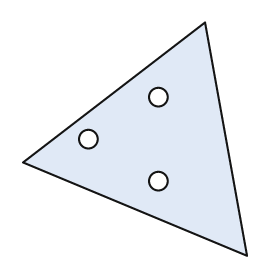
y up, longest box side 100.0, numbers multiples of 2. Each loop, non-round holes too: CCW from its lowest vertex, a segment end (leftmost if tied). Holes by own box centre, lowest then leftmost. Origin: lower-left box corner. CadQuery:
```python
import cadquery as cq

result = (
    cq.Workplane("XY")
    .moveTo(96.0, 0.0)
    .lineTo(78.0, 100.0)
    .lineTo(0.0, 40.0)
    .close()
    .moveTo(58.0, 32.0)
    .circle(4.0)
    .moveTo(28.0, 50.0)
    .circle(4.0)
    .moveTo(58.0, 68.0)
    .circle(4.0)
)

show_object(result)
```